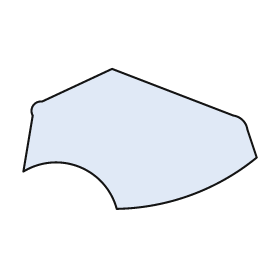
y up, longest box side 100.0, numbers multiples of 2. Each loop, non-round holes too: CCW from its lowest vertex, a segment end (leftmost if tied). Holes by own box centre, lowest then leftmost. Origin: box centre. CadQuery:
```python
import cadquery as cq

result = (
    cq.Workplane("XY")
    .moveTo(-10.0, -30.0)
    .threePointArc((22.0, -24.0), (50.0, -8.0))
    .lineTo(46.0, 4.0)
    .threePointArc((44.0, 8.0), (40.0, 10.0))
    .lineTo(-12.0, 30.0)
    .lineTo(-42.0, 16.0)
    .threePointArc((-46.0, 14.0), (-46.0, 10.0))
    .lineTo(-50.0, -14.0)
    .threePointArc((-26.0, -12.0), (-10.0, -30.0))
    .close()
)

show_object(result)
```